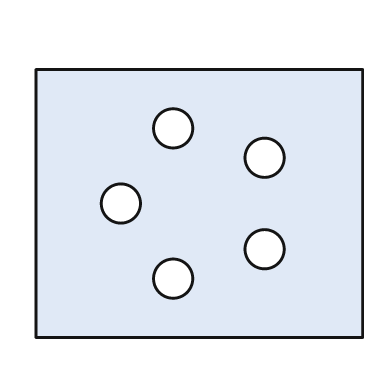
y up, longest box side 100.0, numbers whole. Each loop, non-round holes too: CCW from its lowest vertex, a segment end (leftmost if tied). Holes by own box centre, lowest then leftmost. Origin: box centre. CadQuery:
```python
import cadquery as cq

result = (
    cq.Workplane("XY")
    .moveTo(-50.0, -41.0)
    .lineTo(50.0, -41.0)
    .lineTo(50.0, 41.0)
    .lineTo(-50.0, 41.0)
    .close()
    .moveTo(-8.0, -23.0)
    .circle(6.0)
    .moveTo(20.0, -14.0)
    .circle(6.0)
    .moveTo(-24.0, 0.0)
    .circle(6.0)
    .moveTo(20.0, 14.0)
    .circle(6.0)
    .moveTo(-8.0, 23.0)
    .circle(6.0)
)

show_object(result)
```